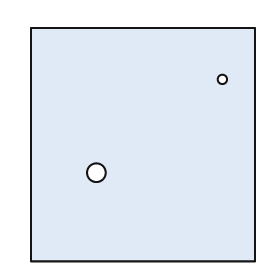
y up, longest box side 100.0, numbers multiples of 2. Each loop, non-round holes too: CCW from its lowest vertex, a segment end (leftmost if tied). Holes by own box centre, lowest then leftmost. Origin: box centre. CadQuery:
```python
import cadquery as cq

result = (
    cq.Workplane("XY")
    .moveTo(-48.0, -50.0)
    .lineTo(48.0, -50.0)
    .lineTo(48.0, 50.0)
    .lineTo(-48.0, 50.0)
    .close()
    .moveTo(-20.0, -12.0)
    .circle(4.0)
    .moveTo(34.0, 28.0)
    .circle(2.0)
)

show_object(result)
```